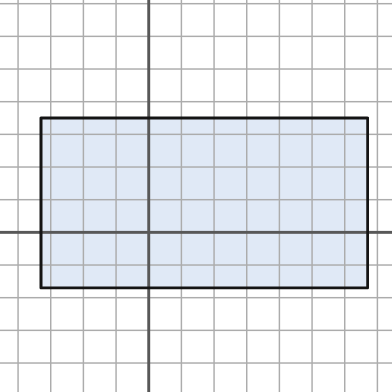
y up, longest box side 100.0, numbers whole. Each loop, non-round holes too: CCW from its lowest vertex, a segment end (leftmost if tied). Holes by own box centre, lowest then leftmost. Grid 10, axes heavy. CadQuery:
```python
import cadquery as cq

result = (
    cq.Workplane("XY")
    .moveTo(-33.0, -17.0)
    .lineTo(67.0, -17.0)
    .lineTo(67.0, 35.0)
    .lineTo(-33.0, 35.0)
    .close()
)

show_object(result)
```